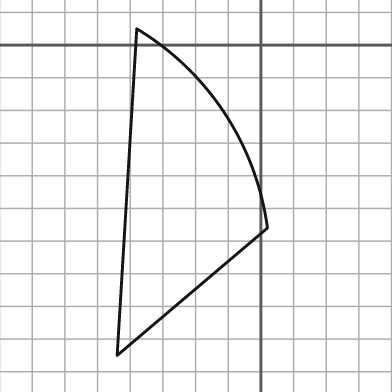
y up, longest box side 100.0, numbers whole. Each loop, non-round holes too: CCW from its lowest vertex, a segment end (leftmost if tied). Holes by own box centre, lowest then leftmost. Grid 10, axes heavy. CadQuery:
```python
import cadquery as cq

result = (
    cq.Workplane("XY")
    .moveTo(-44.0, -95.0)
    .lineTo(2.0, -56.0)
    .threePointArc((-11.0, -21.0), (-38.0, 5.0))
    .close()
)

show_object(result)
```